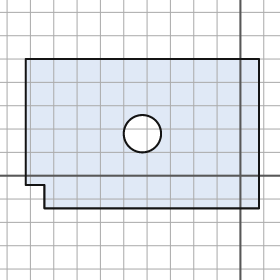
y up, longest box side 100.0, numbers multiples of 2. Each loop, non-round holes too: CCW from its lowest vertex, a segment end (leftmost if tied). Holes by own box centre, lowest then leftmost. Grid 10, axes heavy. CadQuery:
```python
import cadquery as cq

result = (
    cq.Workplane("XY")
    .moveTo(-84.0, -14.0)
    .lineTo(8.0, -14.0)
    .lineTo(8.0, 50.0)
    .lineTo(-92.0, 50.0)
    .lineTo(-92.0, -4.0)
    .lineTo(-84.0, -4.0)
    .close()
    .moveTo(-42.0, 18.0)
    .circle(8.0)
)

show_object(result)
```